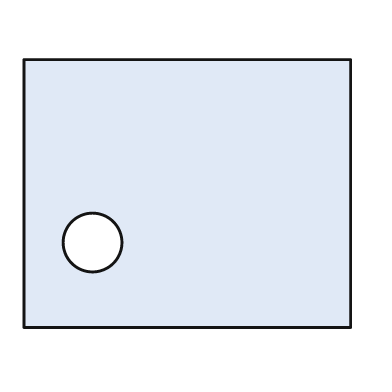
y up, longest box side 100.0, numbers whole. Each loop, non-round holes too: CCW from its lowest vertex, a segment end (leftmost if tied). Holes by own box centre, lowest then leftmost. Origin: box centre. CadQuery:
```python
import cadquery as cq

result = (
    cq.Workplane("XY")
    .moveTo(-50.0, -41.0)
    .lineTo(50.0, -41.0)
    .lineTo(50.0, 41.0)
    .lineTo(-50.0, 41.0)
    .close()
    .moveTo(-29.0, -15.0)
    .circle(9.0)
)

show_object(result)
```